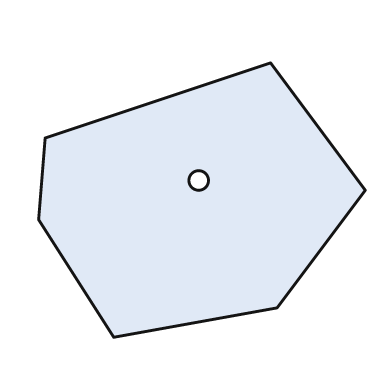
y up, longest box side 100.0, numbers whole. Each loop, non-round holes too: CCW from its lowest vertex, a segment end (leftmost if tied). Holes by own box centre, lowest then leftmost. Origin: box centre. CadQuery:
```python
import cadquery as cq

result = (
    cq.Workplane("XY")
    .moveTo(-27.0, -42.0)
    .lineTo(23.0, -33.0)
    .lineTo(50.0, 3.0)
    .lineTo(21.0, 42.0)
    .lineTo(-48.0, 19.0)
    .lineTo(-50.0, -6.0)
    .close()
    .moveTo(-1.0, 6.0)
    .circle(3.0)
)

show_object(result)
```